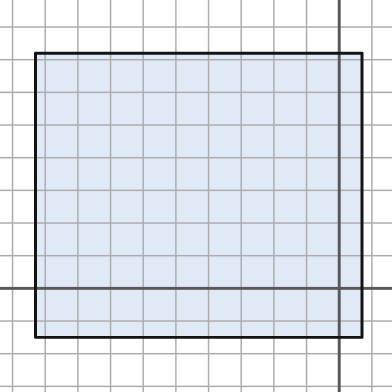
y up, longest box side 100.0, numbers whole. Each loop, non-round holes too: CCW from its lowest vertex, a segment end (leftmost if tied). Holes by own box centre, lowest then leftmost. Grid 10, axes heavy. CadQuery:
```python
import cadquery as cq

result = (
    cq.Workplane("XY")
    .moveTo(-93.0, -15.0)
    .lineTo(7.0, -15.0)
    .lineTo(7.0, 72.0)
    .lineTo(-93.0, 72.0)
    .close()
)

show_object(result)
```